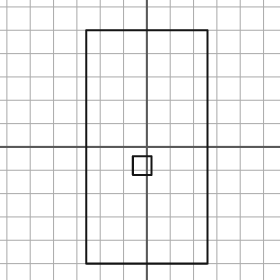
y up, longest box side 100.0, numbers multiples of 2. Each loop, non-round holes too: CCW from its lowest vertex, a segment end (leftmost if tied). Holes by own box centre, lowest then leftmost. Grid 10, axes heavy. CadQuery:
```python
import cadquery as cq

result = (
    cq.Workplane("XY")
    .moveTo(-26.0, -50.0)
    .lineTo(26.0, -50.0)
    .lineTo(26.0, 50.0)
    .lineTo(-26.0, 50.0)
    .close()
    .moveTo(-6.0, -12.0)
    .lineTo(2.0, -12.0)
    .lineTo(2.0, -4.0)
    .lineTo(-6.0, -4.0)
    .close()
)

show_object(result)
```